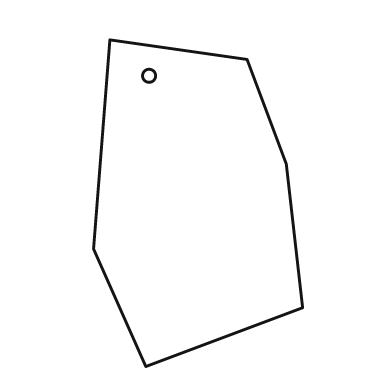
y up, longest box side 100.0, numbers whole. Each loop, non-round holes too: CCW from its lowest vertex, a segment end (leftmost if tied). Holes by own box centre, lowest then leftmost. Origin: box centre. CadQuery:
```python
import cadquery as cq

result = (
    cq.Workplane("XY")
    .moveTo(-16.0, -50.0)
    .lineTo(32.0, -32.0)
    .lineTo(27.0, 12.0)
    .lineTo(15.0, 44.0)
    .lineTo(-27.0, 50.0)
    .lineTo(-32.0, -14.0)
    .close()
    .moveTo(-15.0, 39.0)
    .circle(2.0)
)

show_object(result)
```